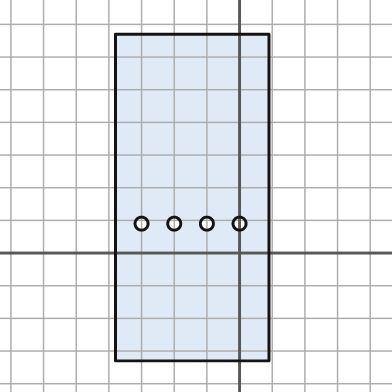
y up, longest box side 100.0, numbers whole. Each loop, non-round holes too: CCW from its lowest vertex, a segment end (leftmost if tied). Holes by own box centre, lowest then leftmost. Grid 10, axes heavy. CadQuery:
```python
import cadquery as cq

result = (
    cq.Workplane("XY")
    .moveTo(-38.0, -33.0)
    .lineTo(9.0, -33.0)
    .lineTo(9.0, 67.0)
    .lineTo(-38.0, 67.0)
    .close()
    .moveTo(-30.0, 9.0)
    .circle(2.0)
    .moveTo(-20.0, 9.0)
    .circle(2.0)
    .moveTo(-10.0, 9.0)
    .circle(2.0)
    .moveTo(0.0, 9.0)
    .circle(2.0)
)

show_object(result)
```